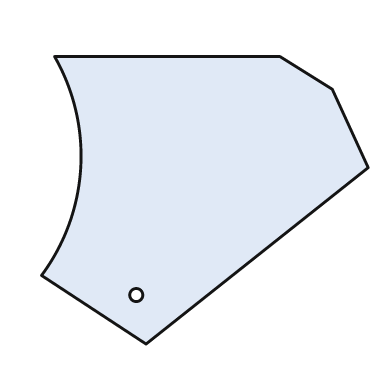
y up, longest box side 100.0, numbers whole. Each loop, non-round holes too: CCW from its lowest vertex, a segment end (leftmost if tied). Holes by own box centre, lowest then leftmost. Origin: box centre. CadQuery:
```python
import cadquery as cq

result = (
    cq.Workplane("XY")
    .moveTo(-18.0, -44.0)
    .lineTo(50.0, 10.0)
    .lineTo(39.0, 34.0)
    .lineTo(23.0, 44.0)
    .lineTo(-46.0, 44.0)
    .threePointArc((-38.0, 10.0), (-50.0, -23.0))
    .close()
    .moveTo(-21.0, -29.0)
    .circle(2.0)
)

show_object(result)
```